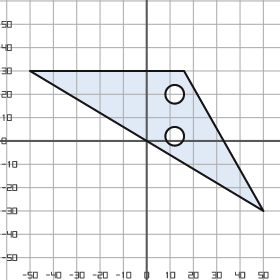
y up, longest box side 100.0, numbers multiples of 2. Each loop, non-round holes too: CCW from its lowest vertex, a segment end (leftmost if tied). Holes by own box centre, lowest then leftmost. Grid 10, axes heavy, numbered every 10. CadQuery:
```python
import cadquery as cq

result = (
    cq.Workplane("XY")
    .moveTo(50.0, -30.0)
    .lineTo(16.0, 30.0)
    .lineTo(-50.0, 30.0)
    .close()
    .moveTo(12.0, 2.0)
    .circle(4.0)
    .moveTo(12.0, 20.0)
    .circle(4.0)
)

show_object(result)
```